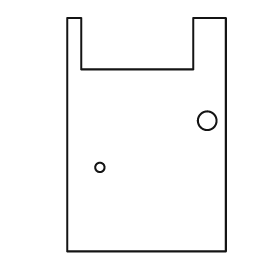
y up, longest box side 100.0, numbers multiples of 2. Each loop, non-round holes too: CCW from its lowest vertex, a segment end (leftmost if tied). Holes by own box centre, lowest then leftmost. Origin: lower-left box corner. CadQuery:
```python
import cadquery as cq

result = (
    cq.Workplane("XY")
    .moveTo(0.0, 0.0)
    .lineTo(68.0, 0.0)
    .lineTo(68.0, 100.0)
    .lineTo(54.0, 100.0)
    .lineTo(54.0, 78.0)
    .lineTo(6.0, 78.0)
    .lineTo(6.0, 100.0)
    .lineTo(0.0, 100.0)
    .close()
    .moveTo(14.0, 36.0)
    .circle(2.0)
    .moveTo(60.0, 56.0)
    .circle(4.0)
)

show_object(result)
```